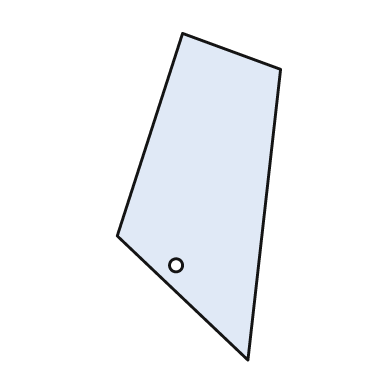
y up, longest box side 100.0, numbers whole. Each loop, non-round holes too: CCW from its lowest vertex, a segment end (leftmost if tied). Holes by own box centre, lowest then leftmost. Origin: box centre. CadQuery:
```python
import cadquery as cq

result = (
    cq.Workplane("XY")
    .moveTo(15.0, -50.0)
    .lineTo(25.0, 39.0)
    .lineTo(-5.0, 50.0)
    .lineTo(-25.0, -12.0)
    .close()
    .moveTo(-7.0, -21.0)
    .circle(2.0)
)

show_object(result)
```